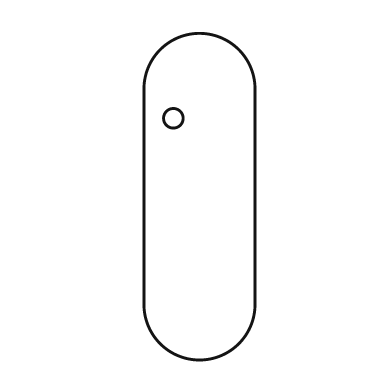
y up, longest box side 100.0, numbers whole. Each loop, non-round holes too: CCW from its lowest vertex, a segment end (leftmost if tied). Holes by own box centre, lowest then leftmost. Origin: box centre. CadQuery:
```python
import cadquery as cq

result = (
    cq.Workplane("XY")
    .moveTo(-17.0, -33.0)
    .threePointArc((0.0, -50.0), (17.0, -33.0))
    .lineTo(17.0, 33.0)
    .threePointArc((0.0, 50.0), (-17.0, 33.0))
    .close()
    .moveTo(-8.0, 24.0)
    .circle(3.0)
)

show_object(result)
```